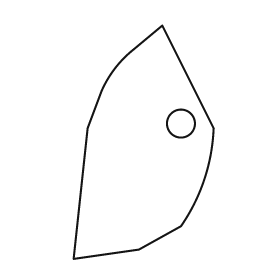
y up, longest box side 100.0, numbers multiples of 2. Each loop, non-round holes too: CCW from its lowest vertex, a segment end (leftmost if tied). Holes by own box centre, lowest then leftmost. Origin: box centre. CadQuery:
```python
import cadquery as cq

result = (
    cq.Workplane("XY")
    .moveTo(-30.0, -50.0)
    .lineTo(-2.0, -46.0)
    .lineTo(16.0, -36.0)
    .threePointArc((26.0, -16.0), (30.0, 6.0))
    .lineTo(8.0, 50.0)
    .lineTo(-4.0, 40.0)
    .threePointArc((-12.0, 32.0), (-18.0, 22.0))
    .lineTo(-24.0, 6.0)
    .close()
    .moveTo(16.0, 8.0)
    .circle(6.0)
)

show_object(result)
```